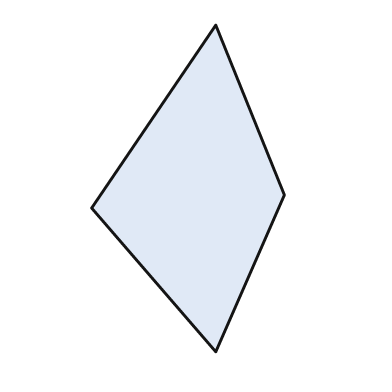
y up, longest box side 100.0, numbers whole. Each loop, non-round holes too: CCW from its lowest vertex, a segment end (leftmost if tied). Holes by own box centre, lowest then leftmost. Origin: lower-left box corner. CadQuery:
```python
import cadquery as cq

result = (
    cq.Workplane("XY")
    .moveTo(38.0, 0.0)
    .lineTo(59.0, 48.0)
    .lineTo(38.0, 100.0)
    .lineTo(0.0, 44.0)
    .close()
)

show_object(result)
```